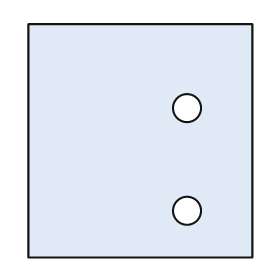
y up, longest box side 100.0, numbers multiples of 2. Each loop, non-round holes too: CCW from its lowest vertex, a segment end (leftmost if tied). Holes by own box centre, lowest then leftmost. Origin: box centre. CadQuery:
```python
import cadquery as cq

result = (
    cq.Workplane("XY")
    .moveTo(-48.0, -50.0)
    .lineTo(48.0, -50.0)
    .lineTo(48.0, 50.0)
    .lineTo(-48.0, 50.0)
    .close()
    .moveTo(20.0, -30.0)
    .circle(6.0)
    .moveTo(20.0, 14.0)
    .circle(6.0)
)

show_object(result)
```